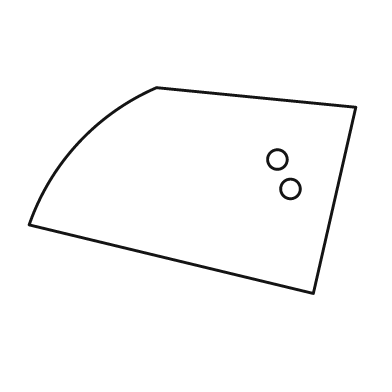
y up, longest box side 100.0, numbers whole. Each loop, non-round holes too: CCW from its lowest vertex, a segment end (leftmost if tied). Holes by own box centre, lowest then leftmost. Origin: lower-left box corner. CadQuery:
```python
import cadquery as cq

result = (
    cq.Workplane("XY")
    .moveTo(87.0, 0.0)
    .lineTo(100.0, 57.0)
    .lineTo(39.0, 63.0)
    .threePointArc((15.0, 46.0), (0.0, 21.0))
    .close()
    .moveTo(80.0, 32.0)
    .circle(3.0)
    .moveTo(76.0, 41.0)
    .circle(3.0)
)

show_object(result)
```